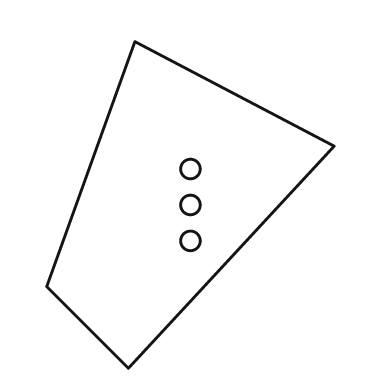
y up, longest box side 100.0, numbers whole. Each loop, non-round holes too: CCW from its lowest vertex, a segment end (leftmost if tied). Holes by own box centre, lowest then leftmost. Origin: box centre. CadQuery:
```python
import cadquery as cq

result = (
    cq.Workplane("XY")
    .moveTo(-19.0, -50.0)
    .lineTo(44.0, 18.0)
    .lineTo(-17.0, 50.0)
    .lineTo(-44.0, -25.0)
    .close()
    .moveTo(0.0, -11.0)
    .circle(3.0)
    .moveTo(0.0, 0.0)
    .circle(3.0)
    .moveTo(0.0, 11.0)
    .circle(3.0)
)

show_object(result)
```